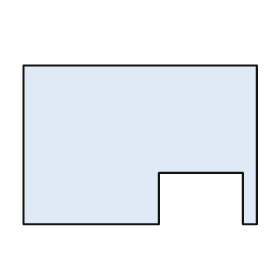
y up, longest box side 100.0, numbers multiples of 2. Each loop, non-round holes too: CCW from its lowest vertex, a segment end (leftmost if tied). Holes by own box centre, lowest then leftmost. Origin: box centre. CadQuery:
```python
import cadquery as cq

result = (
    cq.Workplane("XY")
    .moveTo(-50.0, -34.0)
    .lineTo(8.0, -34.0)
    .lineTo(8.0, -12.0)
    .lineTo(44.0, -12.0)
    .lineTo(44.0, -34.0)
    .lineTo(50.0, -34.0)
    .lineTo(50.0, 34.0)
    .lineTo(-50.0, 34.0)
    .close()
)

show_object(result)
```